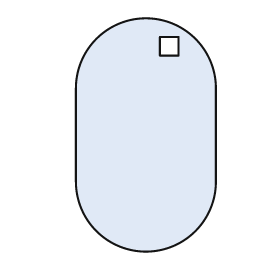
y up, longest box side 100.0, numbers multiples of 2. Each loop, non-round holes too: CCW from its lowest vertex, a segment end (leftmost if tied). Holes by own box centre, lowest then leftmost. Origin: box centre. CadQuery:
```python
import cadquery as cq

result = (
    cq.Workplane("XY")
    .moveTo(-30.0, -20.0)
    .threePointArc((0.0, -50.0), (30.0, -20.0))
    .lineTo(30.0, 20.0)
    .threePointArc((0.0, 50.0), (-30.0, 20.0))
    .close()
    .moveTo(6.0, 34.0)
    .lineTo(14.0, 34.0)
    .lineTo(14.0, 42.0)
    .lineTo(6.0, 42.0)
    .close()
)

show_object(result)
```